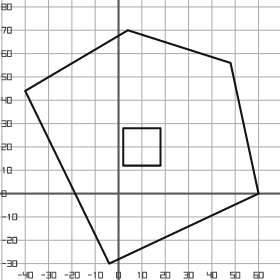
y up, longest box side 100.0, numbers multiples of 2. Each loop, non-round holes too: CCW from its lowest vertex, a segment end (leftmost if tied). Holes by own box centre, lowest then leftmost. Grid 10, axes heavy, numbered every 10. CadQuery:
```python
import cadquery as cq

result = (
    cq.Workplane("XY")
    .moveTo(-4.0, -30.0)
    .lineTo(60.0, 0.0)
    .lineTo(48.0, 56.0)
    .lineTo(4.0, 70.0)
    .lineTo(-40.0, 44.0)
    .close()
    .moveTo(2.0, 12.0)
    .lineTo(18.0, 12.0)
    .lineTo(18.0, 28.0)
    .lineTo(2.0, 28.0)
    .close()
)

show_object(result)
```